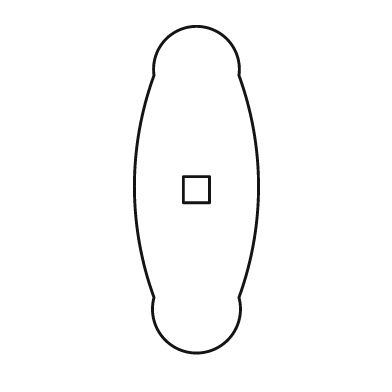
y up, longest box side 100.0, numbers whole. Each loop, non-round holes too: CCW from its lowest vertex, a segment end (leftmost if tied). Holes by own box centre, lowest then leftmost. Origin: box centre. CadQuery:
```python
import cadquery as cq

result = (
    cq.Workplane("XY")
    .moveTo(-13.0, -33.0)
    .threePointArc((0.0, -50.0), (13.0, -33.0))
    .threePointArc((19.0, 1.0), (13.0, 35.0))
    .threePointArc((0.0, 50.0), (-13.0, 35.0))
    .threePointArc((-19.0, 1.0), (-13.0, -33.0))
    .close()
    .moveTo(-4.0, -4.0)
    .lineTo(4.0, -4.0)
    .lineTo(4.0, 4.0)
    .lineTo(-4.0, 4.0)
    .close()
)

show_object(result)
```